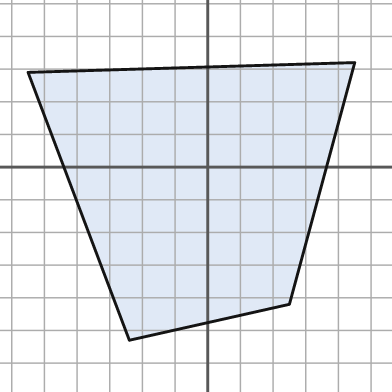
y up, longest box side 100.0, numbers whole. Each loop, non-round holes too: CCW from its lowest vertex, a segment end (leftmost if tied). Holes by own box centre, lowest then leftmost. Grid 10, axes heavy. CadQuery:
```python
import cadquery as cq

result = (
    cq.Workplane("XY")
    .moveTo(-24.0, -53.0)
    .lineTo(25.0, -42.0)
    .lineTo(45.0, 32.0)
    .lineTo(-55.0, 29.0)
    .close()
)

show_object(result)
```